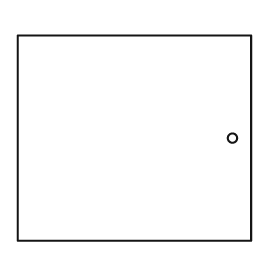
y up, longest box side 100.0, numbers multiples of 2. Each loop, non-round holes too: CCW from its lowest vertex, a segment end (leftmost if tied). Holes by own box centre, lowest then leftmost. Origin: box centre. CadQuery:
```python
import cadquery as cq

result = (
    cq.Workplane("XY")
    .moveTo(-50.0, -44.0)
    .lineTo(50.0, -44.0)
    .lineTo(50.0, 44.0)
    .lineTo(-50.0, 44.0)
    .close()
    .moveTo(42.0, 0.0)
    .circle(2.0)
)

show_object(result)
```